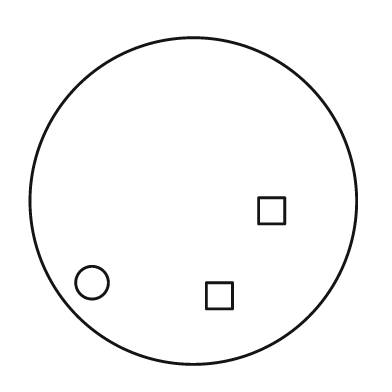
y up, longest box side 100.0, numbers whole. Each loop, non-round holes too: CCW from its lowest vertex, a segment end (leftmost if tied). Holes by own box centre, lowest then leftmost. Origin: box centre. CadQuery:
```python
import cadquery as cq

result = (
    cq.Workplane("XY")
    .moveTo(0.0, 0.0)
    .circle(50.0)
    .moveTo(4.0, -33.0)
    .lineTo(12.0, -33.0)
    .lineTo(12.0, -25.0)
    .lineTo(4.0, -25.0)
    .close()
    .moveTo(-31.0, -25.0)
    .circle(5.0)
    .moveTo(20.0, -7.0)
    .lineTo(28.0, -7.0)
    .lineTo(28.0, 1.0)
    .lineTo(20.0, 1.0)
    .close()
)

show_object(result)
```